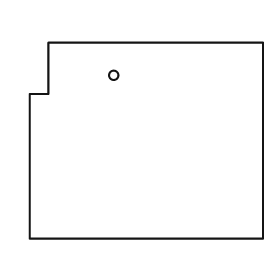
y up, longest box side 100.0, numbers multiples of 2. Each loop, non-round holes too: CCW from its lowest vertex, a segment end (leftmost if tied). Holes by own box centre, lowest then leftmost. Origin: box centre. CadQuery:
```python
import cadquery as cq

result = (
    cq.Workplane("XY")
    .moveTo(-50.0, -42.0)
    .lineTo(50.0, -42.0)
    .lineTo(50.0, 42.0)
    .lineTo(-42.0, 42.0)
    .lineTo(-42.0, 20.0)
    .lineTo(-50.0, 20.0)
    .close()
    .moveTo(-14.0, 28.0)
    .circle(2.0)
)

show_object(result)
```